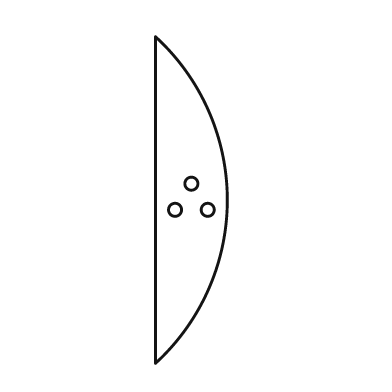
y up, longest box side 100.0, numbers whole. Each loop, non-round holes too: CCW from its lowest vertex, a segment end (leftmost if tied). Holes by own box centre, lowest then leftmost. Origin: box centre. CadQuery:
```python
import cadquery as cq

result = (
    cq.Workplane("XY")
    .moveTo(-11.0, -50.0)
    .threePointArc((11.0, 0.0), (-11.0, 50.0))
    .close()
    .moveTo(-5.0, -3.0)
    .circle(2.0)
    .moveTo(5.0, -3.0)
    .circle(2.0)
    .moveTo(0.0, 5.0)
    .circle(2.0)
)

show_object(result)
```